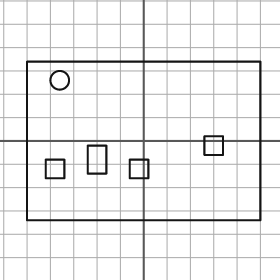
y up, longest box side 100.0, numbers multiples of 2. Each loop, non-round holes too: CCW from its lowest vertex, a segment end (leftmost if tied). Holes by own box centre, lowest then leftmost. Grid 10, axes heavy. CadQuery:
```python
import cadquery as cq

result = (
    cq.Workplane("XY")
    .moveTo(-50.0, -34.0)
    .lineTo(50.0, -34.0)
    .lineTo(50.0, 34.0)
    .lineTo(-50.0, 34.0)
    .close()
    .moveTo(-42.0, -16.0)
    .lineTo(-34.0, -16.0)
    .lineTo(-34.0, -8.0)
    .lineTo(-42.0, -8.0)
    .close()
    .moveTo(-6.0, -16.0)
    .lineTo(2.0, -16.0)
    .lineTo(2.0, -8.0)
    .lineTo(-6.0, -8.0)
    .close()
    .moveTo(-24.0, -14.0)
    .lineTo(-16.0, -14.0)
    .lineTo(-16.0, -2.0)
    .lineTo(-24.0, -2.0)
    .close()
    .moveTo(26.0, -6.0)
    .lineTo(34.0, -6.0)
    .lineTo(34.0, 2.0)
    .lineTo(26.0, 2.0)
    .close()
    .moveTo(-36.0, 26.0)
    .circle(4.0)
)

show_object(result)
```